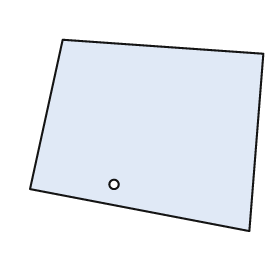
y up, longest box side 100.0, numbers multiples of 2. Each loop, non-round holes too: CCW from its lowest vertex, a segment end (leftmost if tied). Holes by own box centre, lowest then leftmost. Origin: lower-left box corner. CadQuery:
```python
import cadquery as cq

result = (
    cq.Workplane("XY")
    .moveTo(94.0, 0.0)
    .lineTo(100.0, 76.0)
    .lineTo(14.0, 82.0)
    .lineTo(0.0, 18.0)
    .close()
    .moveTo(36.0, 20.0)
    .circle(2.0)
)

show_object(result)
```